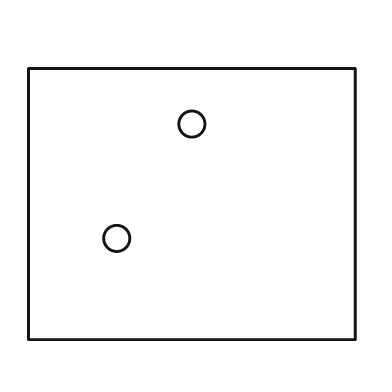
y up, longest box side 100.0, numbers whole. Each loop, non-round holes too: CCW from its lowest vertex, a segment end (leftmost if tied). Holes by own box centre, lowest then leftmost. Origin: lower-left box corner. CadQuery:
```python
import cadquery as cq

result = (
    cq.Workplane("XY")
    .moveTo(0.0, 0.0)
    .lineTo(100.0, 0.0)
    .lineTo(100.0, 83.0)
    .lineTo(0.0, 83.0)
    .close()
    .moveTo(27.0, 31.0)
    .circle(4.0)
    .moveTo(50.0, 66.0)
    .circle(4.0)
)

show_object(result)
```